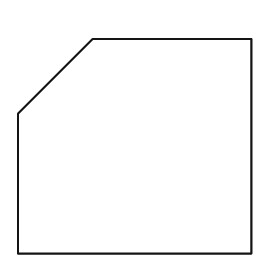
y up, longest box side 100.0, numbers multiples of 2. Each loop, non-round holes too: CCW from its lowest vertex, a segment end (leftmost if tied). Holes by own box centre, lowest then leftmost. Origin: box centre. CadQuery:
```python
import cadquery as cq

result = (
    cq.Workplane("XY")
    .moveTo(-50.0, -46.0)
    .lineTo(50.0, -46.0)
    .lineTo(50.0, 46.0)
    .lineTo(-18.0, 46.0)
    .lineTo(-50.0, 14.0)
    .close()
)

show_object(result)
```